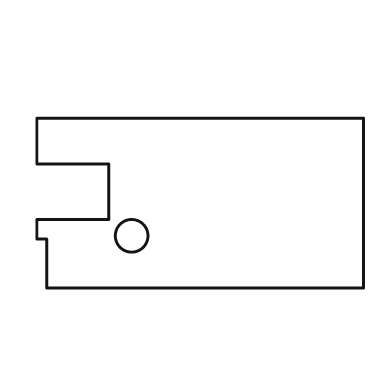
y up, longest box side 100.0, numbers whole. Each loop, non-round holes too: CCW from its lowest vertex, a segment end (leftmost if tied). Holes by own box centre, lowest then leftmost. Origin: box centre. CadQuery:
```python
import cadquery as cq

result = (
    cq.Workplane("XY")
    .moveTo(-47.0, -26.0)
    .lineTo(50.0, -26.0)
    .lineTo(50.0, 26.0)
    .lineTo(-50.0, 26.0)
    .lineTo(-50.0, 12.0)
    .lineTo(-28.0, 12.0)
    .lineTo(-28.0, -5.0)
    .lineTo(-50.0, -5.0)
    .lineTo(-50.0, -11.0)
    .lineTo(-47.0, -11.0)
    .close()
    .moveTo(-21.0, -10.0)
    .circle(5.0)
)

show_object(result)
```